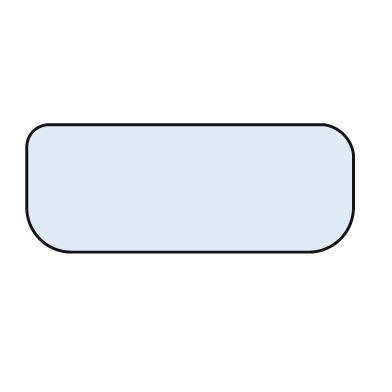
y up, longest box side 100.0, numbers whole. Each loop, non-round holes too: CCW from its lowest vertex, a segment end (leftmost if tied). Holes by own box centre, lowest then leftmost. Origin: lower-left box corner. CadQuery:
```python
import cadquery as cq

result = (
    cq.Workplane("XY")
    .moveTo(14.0, 0.0)
    .lineTo(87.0, 0.0)
    .threePointArc((96.0, 4.0), (100.0, 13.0))
    .lineTo(100.0, 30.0)
    .threePointArc((97.0, 36.0), (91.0, 39.0))
    .lineTo(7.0, 39.0)
    .threePointArc((2.0, 37.0), (0.0, 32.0))
    .lineTo(0.0, 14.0)
    .threePointArc((4.0, 4.0), (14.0, 0.0))
    .close()
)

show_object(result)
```